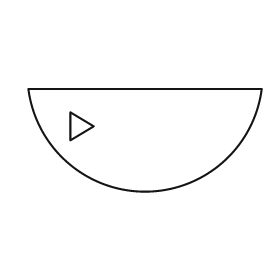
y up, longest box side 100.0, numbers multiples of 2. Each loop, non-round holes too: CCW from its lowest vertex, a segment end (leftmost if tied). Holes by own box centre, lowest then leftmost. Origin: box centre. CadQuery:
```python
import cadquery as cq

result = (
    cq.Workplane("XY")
    .moveTo(-50.0, 22.0)
    .threePointArc((0.0, -22.0), (50.0, 22.0))
    .close()
    .moveTo(-32.0, 0.0)
    .lineTo(-22.0, 6.0)
    .lineTo(-32.0, 12.0)
    .close()
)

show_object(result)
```